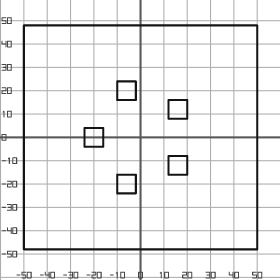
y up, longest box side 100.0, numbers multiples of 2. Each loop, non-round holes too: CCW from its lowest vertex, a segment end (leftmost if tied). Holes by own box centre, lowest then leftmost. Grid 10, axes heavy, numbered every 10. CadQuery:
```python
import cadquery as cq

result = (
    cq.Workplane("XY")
    .moveTo(-50.0, -48.0)
    .lineTo(50.0, -48.0)
    .lineTo(50.0, 48.0)
    .lineTo(-50.0, 48.0)
    .close()
    .moveTo(-10.0, -24.0)
    .lineTo(-2.0, -24.0)
    .lineTo(-2.0, -16.0)
    .lineTo(-10.0, -16.0)
    .close()
    .moveTo(12.0, -16.0)
    .lineTo(20.0, -16.0)
    .lineTo(20.0, -8.0)
    .lineTo(12.0, -8.0)
    .close()
    .moveTo(-24.0, -4.0)
    .lineTo(-16.0, -4.0)
    .lineTo(-16.0, 4.0)
    .lineTo(-24.0, 4.0)
    .close()
    .moveTo(12.0, 8.0)
    .lineTo(20.0, 8.0)
    .lineTo(20.0, 16.0)
    .lineTo(12.0, 16.0)
    .close()
    .moveTo(-10.0, 16.0)
    .lineTo(-2.0, 16.0)
    .lineTo(-2.0, 24.0)
    .lineTo(-10.0, 24.0)
    .close()
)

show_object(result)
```